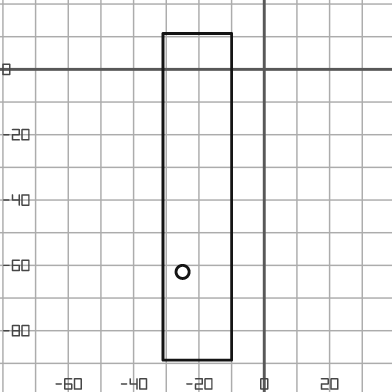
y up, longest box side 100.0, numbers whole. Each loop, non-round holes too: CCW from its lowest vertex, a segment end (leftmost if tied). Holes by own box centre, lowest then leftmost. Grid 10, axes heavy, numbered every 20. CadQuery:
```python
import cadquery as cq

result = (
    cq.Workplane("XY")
    .moveTo(-31.0, -89.0)
    .lineTo(-10.0, -89.0)
    .lineTo(-10.0, 11.0)
    .lineTo(-31.0, 11.0)
    .close()
    .moveTo(-25.0, -62.0)
    .circle(2.0)
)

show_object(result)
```